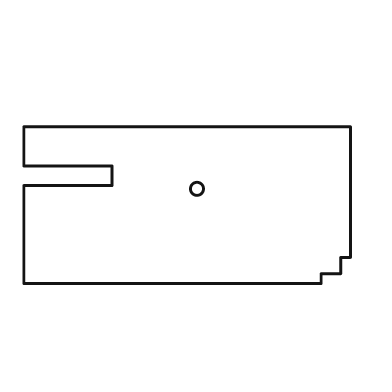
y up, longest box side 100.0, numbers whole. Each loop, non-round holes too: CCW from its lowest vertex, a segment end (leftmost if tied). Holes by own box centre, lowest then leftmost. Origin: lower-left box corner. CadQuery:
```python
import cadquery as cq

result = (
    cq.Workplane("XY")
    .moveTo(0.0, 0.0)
    .lineTo(91.0, 0.0)
    .lineTo(91.0, 3.0)
    .lineTo(97.0, 3.0)
    .lineTo(97.0, 8.0)
    .lineTo(100.0, 8.0)
    .lineTo(100.0, 48.0)
    .lineTo(0.0, 48.0)
    .lineTo(0.0, 36.0)
    .lineTo(27.0, 36.0)
    .lineTo(27.0, 30.0)
    .lineTo(0.0, 30.0)
    .close()
    .moveTo(53.0, 29.0)
    .circle(2.0)
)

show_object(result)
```